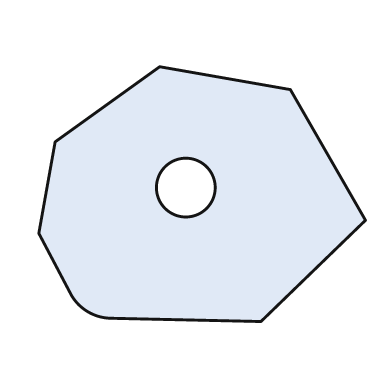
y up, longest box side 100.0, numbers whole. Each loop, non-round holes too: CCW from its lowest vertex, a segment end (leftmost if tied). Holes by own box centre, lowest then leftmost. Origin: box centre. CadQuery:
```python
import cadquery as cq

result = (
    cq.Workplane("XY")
    .moveTo(18.0, -39.0)
    .lineTo(50.0, -8.0)
    .lineTo(27.0, 32.0)
    .lineTo(-13.0, 39.0)
    .lineTo(-45.0, 16.0)
    .lineTo(-50.0, -12.0)
    .lineTo(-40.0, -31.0)
    .threePointArc((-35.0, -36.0), (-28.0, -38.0))
    .close()
    .moveTo(-5.0, 2.0)
    .circle(9.0)
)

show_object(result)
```